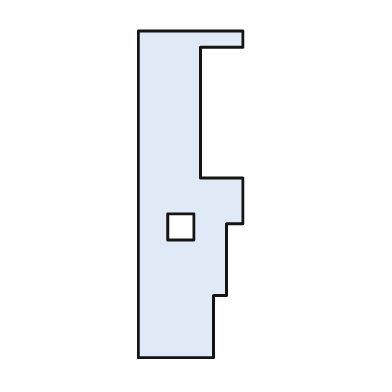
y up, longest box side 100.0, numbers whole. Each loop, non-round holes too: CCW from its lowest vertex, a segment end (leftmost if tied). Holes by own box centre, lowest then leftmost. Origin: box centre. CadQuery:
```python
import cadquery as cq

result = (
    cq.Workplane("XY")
    .moveTo(-16.0, -50.0)
    .lineTo(7.0, -50.0)
    .lineTo(7.0, -31.0)
    .lineTo(11.0, -31.0)
    .lineTo(11.0, -9.0)
    .lineTo(16.0, -9.0)
    .lineTo(16.0, 5.0)
    .lineTo(3.0, 5.0)
    .lineTo(3.0, 45.0)
    .lineTo(16.0, 45.0)
    .lineTo(16.0, 50.0)
    .lineTo(-16.0, 50.0)
    .close()
    .moveTo(-7.0, -14.0)
    .lineTo(1.0, -14.0)
    .lineTo(1.0, -6.0)
    .lineTo(-7.0, -6.0)
    .close()
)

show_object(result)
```